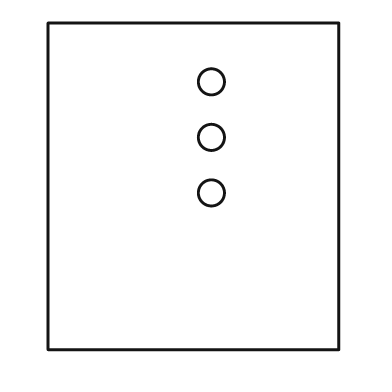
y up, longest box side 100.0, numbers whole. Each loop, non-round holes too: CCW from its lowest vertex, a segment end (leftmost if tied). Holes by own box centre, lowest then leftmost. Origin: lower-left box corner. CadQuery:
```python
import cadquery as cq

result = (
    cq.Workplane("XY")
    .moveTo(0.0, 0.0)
    .lineTo(89.0, 0.0)
    .lineTo(89.0, 100.0)
    .lineTo(0.0, 100.0)
    .close()
    .moveTo(50.0, 48.0)
    .circle(4.0)
    .moveTo(50.0, 65.0)
    .circle(4.0)
    .moveTo(50.0, 82.0)
    .circle(4.0)
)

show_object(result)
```